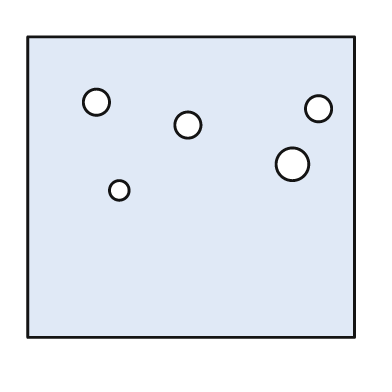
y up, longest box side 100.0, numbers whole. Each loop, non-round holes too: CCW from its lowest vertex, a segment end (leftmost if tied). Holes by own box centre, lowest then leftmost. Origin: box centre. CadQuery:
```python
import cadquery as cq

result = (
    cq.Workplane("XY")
    .moveTo(-50.0, -46.0)
    .lineTo(50.0, -46.0)
    .lineTo(50.0, 46.0)
    .lineTo(-50.0, 46.0)
    .close()
    .moveTo(-22.0, -1.0)
    .circle(3.0)
    .moveTo(31.0, 7.0)
    .circle(5.0)
    .moveTo(-1.0, 19.0)
    .circle(4.0)
    .moveTo(39.0, 24.0)
    .circle(4.0)
    .moveTo(-29.0, 26.0)
    .circle(4.0)
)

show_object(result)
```